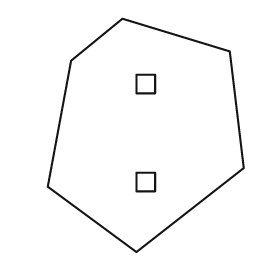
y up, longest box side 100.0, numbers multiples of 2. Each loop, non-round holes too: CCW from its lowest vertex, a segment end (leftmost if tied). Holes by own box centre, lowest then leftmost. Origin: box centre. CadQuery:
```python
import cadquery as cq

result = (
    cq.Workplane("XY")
    .moveTo(-4.0, -50.0)
    .lineTo(42.0, -14.0)
    .lineTo(36.0, 36.0)
    .lineTo(-10.0, 50.0)
    .lineTo(-32.0, 32.0)
    .lineTo(-42.0, -22.0)
    .close()
    .moveTo(-4.0, -24.0)
    .lineTo(4.0, -24.0)
    .lineTo(4.0, -16.0)
    .lineTo(-4.0, -16.0)
    .close()
    .moveTo(-4.0, 18.0)
    .lineTo(4.0, 18.0)
    .lineTo(4.0, 26.0)
    .lineTo(-4.0, 26.0)
    .close()
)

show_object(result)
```